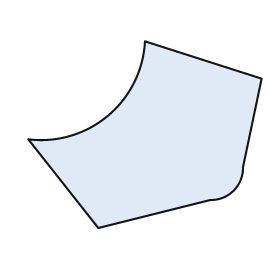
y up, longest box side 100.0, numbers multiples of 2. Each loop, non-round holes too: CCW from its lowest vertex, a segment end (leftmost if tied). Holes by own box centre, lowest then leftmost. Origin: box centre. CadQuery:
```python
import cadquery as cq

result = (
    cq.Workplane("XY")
    .moveTo(-20.0, -40.0)
    .lineTo(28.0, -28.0)
    .threePointArc((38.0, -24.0), (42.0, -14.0))
    .lineTo(50.0, 24.0)
    .lineTo(0.0, 40.0)
    .threePointArc((-16.0, 8.0), (-50.0, -2.0))
    .close()
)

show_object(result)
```